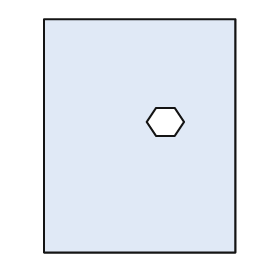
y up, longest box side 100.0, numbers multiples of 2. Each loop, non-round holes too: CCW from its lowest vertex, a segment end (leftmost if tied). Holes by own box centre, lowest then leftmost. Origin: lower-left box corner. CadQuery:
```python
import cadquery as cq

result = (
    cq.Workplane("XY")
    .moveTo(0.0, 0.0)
    .lineTo(82.0, 0.0)
    .lineTo(82.0, 100.0)
    .lineTo(0.0, 100.0)
    .close()
    .moveTo(48.0, 50.0)
    .lineTo(56.0, 50.0)
    .lineTo(60.0, 56.0)
    .lineTo(56.0, 62.0)
    .lineTo(48.0, 62.0)
    .lineTo(44.0, 56.0)
    .close()
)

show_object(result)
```